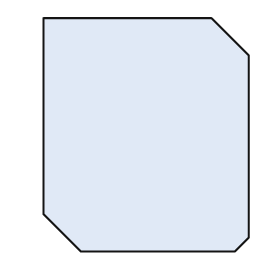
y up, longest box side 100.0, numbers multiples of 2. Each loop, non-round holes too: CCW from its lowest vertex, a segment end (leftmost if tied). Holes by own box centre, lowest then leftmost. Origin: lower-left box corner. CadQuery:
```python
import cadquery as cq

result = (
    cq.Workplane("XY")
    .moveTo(16.0, 0.0)
    .lineTo(82.0, 0.0)
    .lineTo(88.0, 6.0)
    .lineTo(88.0, 84.0)
    .lineTo(72.0, 100.0)
    .lineTo(0.0, 100.0)
    .lineTo(0.0, 16.0)
    .close()
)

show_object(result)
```